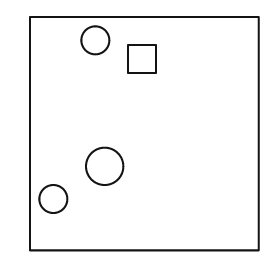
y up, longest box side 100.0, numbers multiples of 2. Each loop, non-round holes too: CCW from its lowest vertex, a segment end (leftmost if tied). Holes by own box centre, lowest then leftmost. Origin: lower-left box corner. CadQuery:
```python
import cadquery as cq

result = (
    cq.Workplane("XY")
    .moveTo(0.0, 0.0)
    .lineTo(98.0, 0.0)
    .lineTo(98.0, 100.0)
    .lineTo(0.0, 100.0)
    .close()
    .moveTo(10.0, 22.0)
    .circle(6.0)
    .moveTo(32.0, 36.0)
    .circle(8.0)
    .moveTo(42.0, 76.0)
    .lineTo(54.0, 76.0)
    .lineTo(54.0, 88.0)
    .lineTo(42.0, 88.0)
    .close()
    .moveTo(28.0, 90.0)
    .circle(6.0)
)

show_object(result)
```